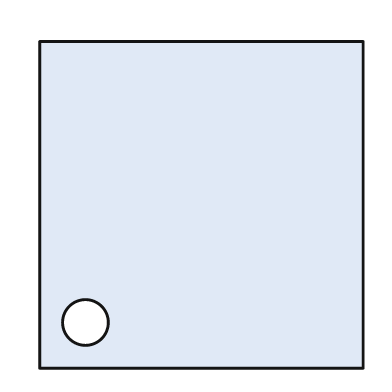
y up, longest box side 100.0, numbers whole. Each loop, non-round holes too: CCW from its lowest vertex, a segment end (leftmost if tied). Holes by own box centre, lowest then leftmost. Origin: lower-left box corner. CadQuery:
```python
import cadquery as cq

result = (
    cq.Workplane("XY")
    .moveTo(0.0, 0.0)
    .lineTo(99.0, 0.0)
    .lineTo(99.0, 100.0)
    .lineTo(0.0, 100.0)
    .close()
    .moveTo(14.0, 14.0)
    .circle(7.0)
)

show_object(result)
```